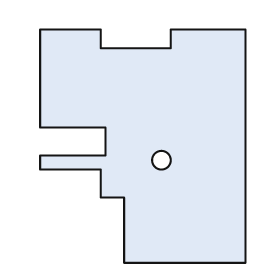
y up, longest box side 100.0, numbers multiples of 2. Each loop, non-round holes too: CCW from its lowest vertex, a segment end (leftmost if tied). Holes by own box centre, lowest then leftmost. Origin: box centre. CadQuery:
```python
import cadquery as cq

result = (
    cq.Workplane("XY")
    .moveTo(-8.0, -50.0)
    .lineTo(44.0, -50.0)
    .lineTo(44.0, 50.0)
    .lineTo(12.0, 50.0)
    .lineTo(12.0, 42.0)
    .lineTo(-18.0, 42.0)
    .lineTo(-18.0, 50.0)
    .lineTo(-44.0, 50.0)
    .lineTo(-44.0, 8.0)
    .lineTo(-16.0, 8.0)
    .lineTo(-16.0, -4.0)
    .lineTo(-44.0, -4.0)
    .lineTo(-44.0, -10.0)
    .lineTo(-18.0, -10.0)
    .lineTo(-18.0, -22.0)
    .lineTo(-8.0, -22.0)
    .close()
    .moveTo(8.0, -6.0)
    .circle(4.0)
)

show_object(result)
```